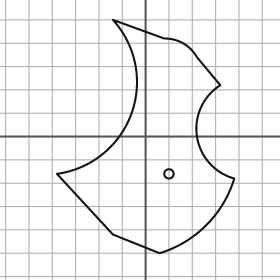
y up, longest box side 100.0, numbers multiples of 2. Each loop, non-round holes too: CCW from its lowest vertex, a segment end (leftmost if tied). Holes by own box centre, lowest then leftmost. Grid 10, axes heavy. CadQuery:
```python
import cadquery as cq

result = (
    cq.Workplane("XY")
    .moveTo(6.0, -50.0)
    .threePointArc((26.0, -38.0), (38.0, -18.0))
    .threePointArc((22.0, 0.0), (32.0, 22.0))
    .lineTo(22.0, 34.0)
    .threePointArc((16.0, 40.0), (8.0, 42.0))
    .lineTo(-14.0, 50.0)
    .threePointArc((-6.0, 10.0), (-38.0, -16.0))
    .lineTo(-14.0, -42.0)
    .close()
    .moveTo(10.0, -16.0)
    .circle(2.0)
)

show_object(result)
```